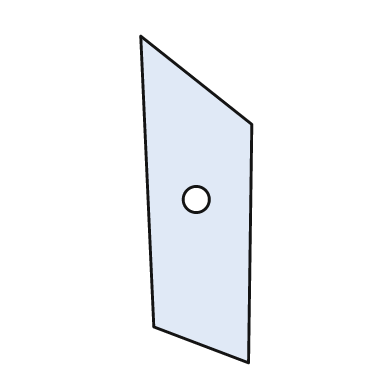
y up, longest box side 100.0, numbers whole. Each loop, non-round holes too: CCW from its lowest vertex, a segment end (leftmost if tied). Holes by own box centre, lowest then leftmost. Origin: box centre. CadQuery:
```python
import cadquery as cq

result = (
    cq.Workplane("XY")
    .moveTo(16.0, -50.0)
    .lineTo(17.0, 23.0)
    .lineTo(-17.0, 50.0)
    .lineTo(-13.0, -39.0)
    .close()
    .moveTo(0.0, 0.0)
    .circle(4.0)
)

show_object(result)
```